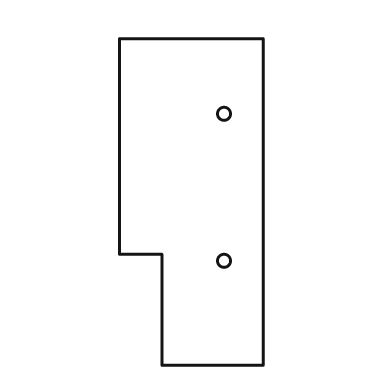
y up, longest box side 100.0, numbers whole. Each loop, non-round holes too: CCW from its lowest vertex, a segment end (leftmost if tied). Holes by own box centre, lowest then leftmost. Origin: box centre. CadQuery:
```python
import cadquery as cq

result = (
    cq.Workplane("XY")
    .moveTo(-9.0, -50.0)
    .lineTo(22.0, -50.0)
    .lineTo(22.0, 50.0)
    .lineTo(-22.0, 50.0)
    .lineTo(-22.0, -16.0)
    .lineTo(-9.0, -16.0)
    .close()
    .moveTo(10.0, -18.0)
    .circle(2.0)
    .moveTo(10.0, 27.0)
    .circle(2.0)
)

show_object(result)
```